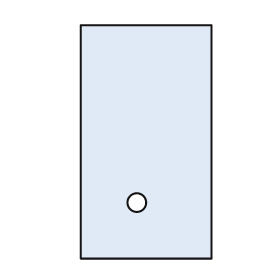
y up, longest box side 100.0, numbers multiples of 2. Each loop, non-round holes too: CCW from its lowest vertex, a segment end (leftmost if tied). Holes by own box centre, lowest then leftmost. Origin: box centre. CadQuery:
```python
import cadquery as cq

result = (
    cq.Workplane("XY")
    .moveTo(-28.0, -50.0)
    .lineTo(28.0, -50.0)
    .lineTo(28.0, 50.0)
    .lineTo(-28.0, 50.0)
    .close()
    .moveTo(-4.0, -26.0)
    .circle(4.0)
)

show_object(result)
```